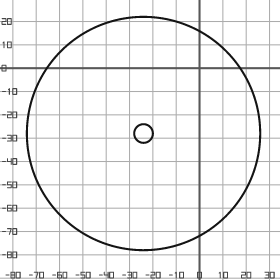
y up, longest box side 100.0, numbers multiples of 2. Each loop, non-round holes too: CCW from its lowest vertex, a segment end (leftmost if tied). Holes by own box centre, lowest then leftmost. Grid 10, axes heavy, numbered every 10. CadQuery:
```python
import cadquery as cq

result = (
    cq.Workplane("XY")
    .moveTo(-24.0, -28.0)
    .circle(50.0)
    .moveTo(-24.0, -28.0)
    .circle(4.0)
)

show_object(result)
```